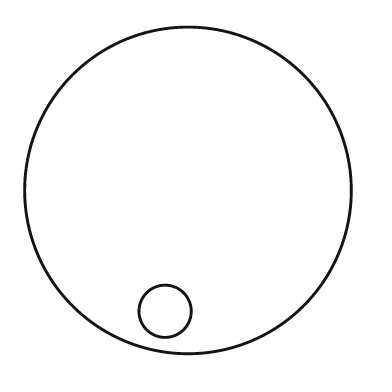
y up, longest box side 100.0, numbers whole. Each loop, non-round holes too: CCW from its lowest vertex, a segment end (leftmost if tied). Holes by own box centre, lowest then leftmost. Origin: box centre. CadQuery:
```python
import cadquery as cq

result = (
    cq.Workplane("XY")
    .moveTo(0.0, 0.0)
    .circle(50.0)
    .moveTo(-7.0, -37.0)
    .circle(8.0)
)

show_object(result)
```